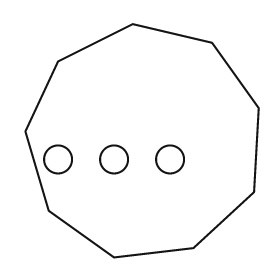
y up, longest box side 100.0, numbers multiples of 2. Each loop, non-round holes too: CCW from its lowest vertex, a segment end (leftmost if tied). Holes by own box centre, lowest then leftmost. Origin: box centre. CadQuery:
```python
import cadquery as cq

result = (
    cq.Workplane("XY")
    .moveTo(-12.0, -50.0)
    .lineTo(22.0, -46.0)
    .lineTo(48.0, -22.0)
    .lineTo(50.0, 14.0)
    .lineTo(30.0, 42.0)
    .lineTo(-4.0, 50.0)
    .lineTo(-36.0, 34.0)
    .lineTo(-50.0, 4.0)
    .lineTo(-40.0, -30.0)
    .close()
    .moveTo(-36.0, -8.0)
    .circle(6.0)
    .moveTo(-12.0, -8.0)
    .circle(6.0)
    .moveTo(12.0, -8.0)
    .circle(6.0)
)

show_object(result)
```